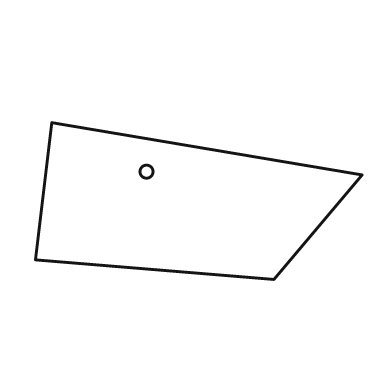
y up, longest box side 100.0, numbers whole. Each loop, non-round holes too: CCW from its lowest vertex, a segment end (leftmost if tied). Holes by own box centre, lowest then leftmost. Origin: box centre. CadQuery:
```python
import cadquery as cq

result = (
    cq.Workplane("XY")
    .moveTo(23.0, -24.0)
    .lineTo(50.0, 8.0)
    .lineTo(-45.0, 24.0)
    .lineTo(-50.0, -18.0)
    .close()
    .moveTo(-16.0, 9.0)
    .circle(2.0)
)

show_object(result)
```